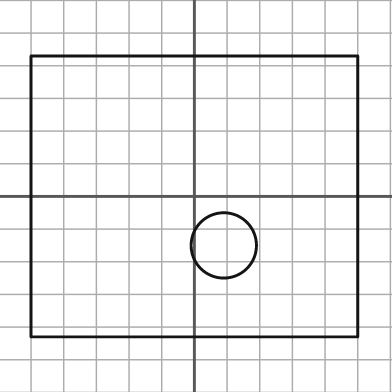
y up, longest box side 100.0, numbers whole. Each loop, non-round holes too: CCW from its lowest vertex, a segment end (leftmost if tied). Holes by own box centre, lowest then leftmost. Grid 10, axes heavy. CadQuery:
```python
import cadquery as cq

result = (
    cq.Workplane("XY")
    .moveTo(-50.0, -43.0)
    .lineTo(50.0, -43.0)
    .lineTo(50.0, 43.0)
    .lineTo(-50.0, 43.0)
    .close()
    .moveTo(9.0, -15.0)
    .circle(10.0)
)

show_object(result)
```